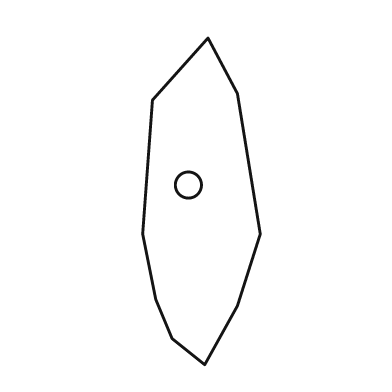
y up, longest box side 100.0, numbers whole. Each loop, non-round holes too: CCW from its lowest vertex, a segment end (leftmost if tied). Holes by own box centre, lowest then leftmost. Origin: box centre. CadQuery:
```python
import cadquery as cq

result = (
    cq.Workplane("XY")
    .moveTo(1.0, -50.0)
    .lineTo(11.0, -32.0)
    .lineTo(18.0, -10.0)
    .lineTo(11.0, 33.0)
    .lineTo(2.0, 50.0)
    .lineTo(-15.0, 31.0)
    .lineTo(-18.0, -10.0)
    .lineTo(-14.0, -30.0)
    .lineTo(-9.0, -42.0)
    .close()
    .moveTo(-4.0, 5.0)
    .circle(4.0)
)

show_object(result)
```